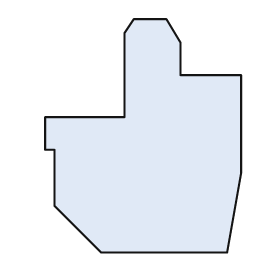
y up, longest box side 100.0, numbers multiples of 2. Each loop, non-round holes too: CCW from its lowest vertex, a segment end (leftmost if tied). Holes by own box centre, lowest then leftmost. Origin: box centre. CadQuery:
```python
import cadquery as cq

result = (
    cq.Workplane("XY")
    .moveTo(-18.0, -50.0)
    .lineTo(36.0, -50.0)
    .lineTo(42.0, -16.0)
    .lineTo(42.0, 26.0)
    .lineTo(16.0, 26.0)
    .lineTo(16.0, 40.0)
    .lineTo(10.0, 50.0)
    .lineTo(-4.0, 50.0)
    .lineTo(-8.0, 44.0)
    .lineTo(-8.0, 8.0)
    .lineTo(-42.0, 8.0)
    .lineTo(-42.0, -6.0)
    .lineTo(-38.0, -6.0)
    .lineTo(-38.0, -30.0)
    .close()
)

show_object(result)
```